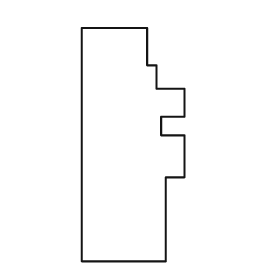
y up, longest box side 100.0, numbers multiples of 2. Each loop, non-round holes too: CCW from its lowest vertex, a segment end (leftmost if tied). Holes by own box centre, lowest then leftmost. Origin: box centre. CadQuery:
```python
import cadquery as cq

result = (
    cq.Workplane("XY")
    .moveTo(-22.0, -50.0)
    .lineTo(14.0, -50.0)
    .lineTo(14.0, -14.0)
    .lineTo(22.0, -14.0)
    .lineTo(22.0, 4.0)
    .lineTo(12.0, 4.0)
    .lineTo(12.0, 12.0)
    .lineTo(22.0, 12.0)
    .lineTo(22.0, 24.0)
    .lineTo(10.0, 24.0)
    .lineTo(10.0, 34.0)
    .lineTo(6.0, 34.0)
    .lineTo(6.0, 50.0)
    .lineTo(-22.0, 50.0)
    .close()
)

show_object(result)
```